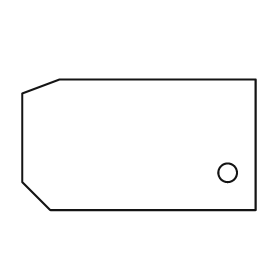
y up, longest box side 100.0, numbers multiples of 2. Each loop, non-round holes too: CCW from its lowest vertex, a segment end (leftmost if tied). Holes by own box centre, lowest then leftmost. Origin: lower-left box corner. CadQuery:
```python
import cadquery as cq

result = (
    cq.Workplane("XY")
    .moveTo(12.0, 0.0)
    .lineTo(100.0, 0.0)
    .lineTo(100.0, 56.0)
    .lineTo(16.0, 56.0)
    .lineTo(0.0, 50.0)
    .lineTo(0.0, 12.0)
    .close()
    .moveTo(88.0, 16.0)
    .circle(4.0)
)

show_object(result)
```